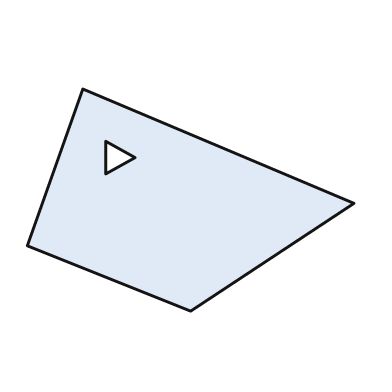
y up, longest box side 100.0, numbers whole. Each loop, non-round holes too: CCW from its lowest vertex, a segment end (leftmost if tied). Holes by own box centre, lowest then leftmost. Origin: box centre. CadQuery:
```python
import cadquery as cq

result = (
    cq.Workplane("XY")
    .moveTo(0.0, -34.0)
    .lineTo(50.0, -1.0)
    .lineTo(-33.0, 34.0)
    .lineTo(-50.0, -14.0)
    .close()
    .moveTo(-26.0, 8.0)
    .lineTo(-17.0, 13.0)
    .lineTo(-26.0, 18.0)
    .close()
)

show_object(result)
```